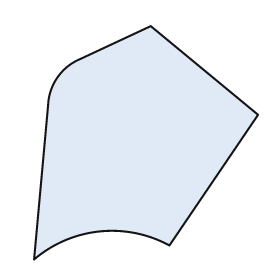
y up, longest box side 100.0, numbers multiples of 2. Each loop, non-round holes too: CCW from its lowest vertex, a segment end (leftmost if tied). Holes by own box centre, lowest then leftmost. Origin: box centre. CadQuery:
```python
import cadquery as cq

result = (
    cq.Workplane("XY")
    .moveTo(-48.0, -50.0)
    .threePointArc((-20.0, -38.0), (10.0, -44.0))
    .lineTo(48.0, 12.0)
    .lineTo(2.0, 50.0)
    .lineTo(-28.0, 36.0)
    .threePointArc((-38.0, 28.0), (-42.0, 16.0))
    .close()
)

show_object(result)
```